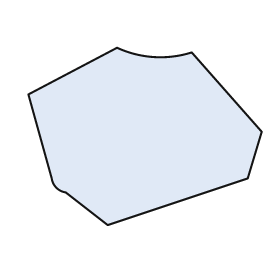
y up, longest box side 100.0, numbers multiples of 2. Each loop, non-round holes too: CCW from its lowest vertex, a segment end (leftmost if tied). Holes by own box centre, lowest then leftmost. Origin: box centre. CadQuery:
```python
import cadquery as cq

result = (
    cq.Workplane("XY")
    .moveTo(-16.0, -38.0)
    .lineTo(44.0, -18.0)
    .lineTo(50.0, 2.0)
    .lineTo(20.0, 36.0)
    .threePointArc((4.0, 34.0), (-12.0, 38.0))
    .lineTo(-50.0, 18.0)
    .lineTo(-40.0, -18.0)
    .threePointArc((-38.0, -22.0), (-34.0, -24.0))
    .close()
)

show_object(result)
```